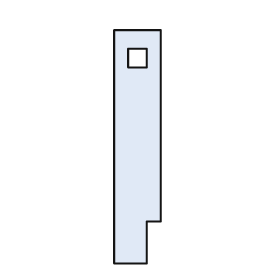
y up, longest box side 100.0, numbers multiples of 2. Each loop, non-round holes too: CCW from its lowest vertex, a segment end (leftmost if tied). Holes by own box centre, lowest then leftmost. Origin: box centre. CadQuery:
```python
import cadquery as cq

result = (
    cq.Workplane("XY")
    .moveTo(-10.0, -50.0)
    .lineTo(4.0, -50.0)
    .lineTo(4.0, -32.0)
    .lineTo(10.0, -32.0)
    .lineTo(10.0, 50.0)
    .lineTo(-10.0, 50.0)
    .close()
    .moveTo(-4.0, 34.0)
    .lineTo(4.0, 34.0)
    .lineTo(4.0, 42.0)
    .lineTo(-4.0, 42.0)
    .close()
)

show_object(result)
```